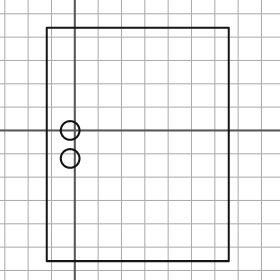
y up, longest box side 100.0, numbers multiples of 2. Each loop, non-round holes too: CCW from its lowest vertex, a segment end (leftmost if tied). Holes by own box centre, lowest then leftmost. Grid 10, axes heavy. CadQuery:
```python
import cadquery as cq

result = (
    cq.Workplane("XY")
    .moveTo(-12.0, -56.0)
    .lineTo(66.0, -56.0)
    .lineTo(66.0, 44.0)
    .lineTo(-12.0, 44.0)
    .close()
    .moveTo(-2.0, -12.0)
    .circle(4.0)
    .moveTo(-2.0, 0.0)
    .circle(4.0)
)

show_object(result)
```